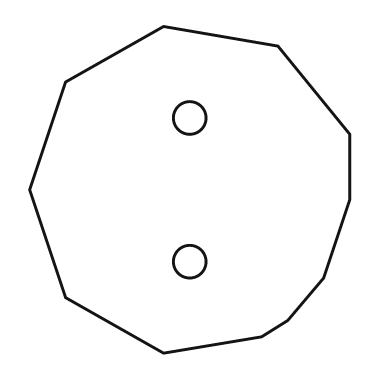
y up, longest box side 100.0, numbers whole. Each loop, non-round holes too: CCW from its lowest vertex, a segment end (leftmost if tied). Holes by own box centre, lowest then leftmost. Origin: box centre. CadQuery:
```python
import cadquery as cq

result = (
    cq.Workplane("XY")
    .moveTo(-8.0, -50.0)
    .lineTo(22.0, -45.0)
    .lineTo(30.0, -40.0)
    .lineTo(41.0, -27.0)
    .lineTo(49.0, -3.0)
    .lineTo(49.0, 17.0)
    .lineTo(27.0, 44.0)
    .lineTo(-8.0, 50.0)
    .lineTo(-38.0, 33.0)
    .lineTo(-49.0, 0.0)
    .lineTo(-38.0, -33.0)
    .close()
    .moveTo(0.0, -22.0)
    .circle(5.0)
    .moveTo(0.0, 22.0)
    .circle(5.0)
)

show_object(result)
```